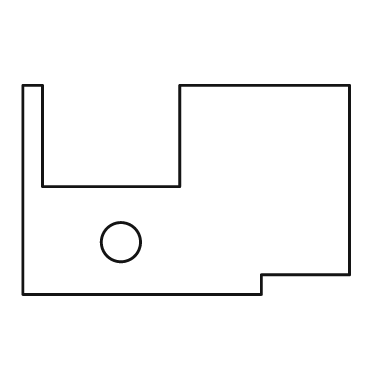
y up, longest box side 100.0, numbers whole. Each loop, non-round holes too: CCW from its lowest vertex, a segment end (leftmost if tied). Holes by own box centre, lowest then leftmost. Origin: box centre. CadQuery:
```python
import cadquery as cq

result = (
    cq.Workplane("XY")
    .moveTo(-50.0, -32.0)
    .lineTo(23.0, -32.0)
    .lineTo(23.0, -26.0)
    .lineTo(50.0, -26.0)
    .lineTo(50.0, 32.0)
    .lineTo(-2.0, 32.0)
    .lineTo(-2.0, 1.0)
    .lineTo(-44.0, 1.0)
    .lineTo(-44.0, 32.0)
    .lineTo(-50.0, 32.0)
    .close()
    .moveTo(-20.0, -16.0)
    .circle(6.0)
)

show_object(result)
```